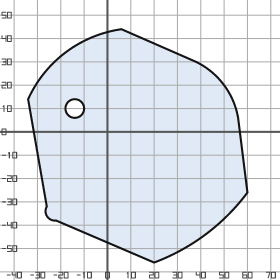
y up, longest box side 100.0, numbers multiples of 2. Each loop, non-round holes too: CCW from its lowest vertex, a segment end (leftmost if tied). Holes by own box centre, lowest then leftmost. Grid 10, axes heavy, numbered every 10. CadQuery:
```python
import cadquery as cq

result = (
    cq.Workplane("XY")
    .moveTo(20.0, -56.0)
    .threePointArc((42.0, -44.0), (60.0, -26.0))
    .lineTo(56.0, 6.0)
    .threePointArc((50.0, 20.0), (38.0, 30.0))
    .lineTo(6.0, 44.0)
    .threePointArc((-18.0, 34.0), (-34.0, 14.0))
    .lineTo(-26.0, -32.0)
    .threePointArc((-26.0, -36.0), (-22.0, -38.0))
    .close()
    .moveTo(-14.0, 10.0)
    .circle(4.0)
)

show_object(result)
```